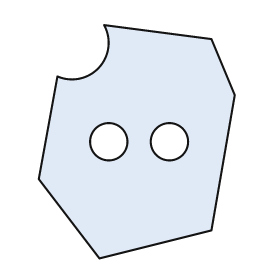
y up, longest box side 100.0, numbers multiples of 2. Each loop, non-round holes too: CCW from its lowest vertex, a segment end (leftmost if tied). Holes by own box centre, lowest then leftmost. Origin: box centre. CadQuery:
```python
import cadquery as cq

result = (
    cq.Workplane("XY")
    .moveTo(-16.0, -50.0)
    .lineTo(32.0, -38.0)
    .lineTo(42.0, 20.0)
    .lineTo(32.0, 44.0)
    .lineTo(-14.0, 50.0)
    .threePointArc((-16.0, 32.0), (-34.0, 28.0))
    .lineTo(-42.0, -16.0)
    .close()
    .moveTo(-12.0, 0.0)
    .circle(8.0)
    .moveTo(14.0, 0.0)
    .circle(8.0)
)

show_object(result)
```